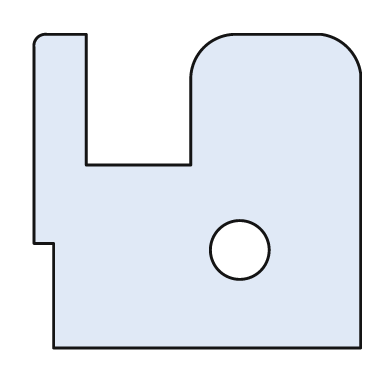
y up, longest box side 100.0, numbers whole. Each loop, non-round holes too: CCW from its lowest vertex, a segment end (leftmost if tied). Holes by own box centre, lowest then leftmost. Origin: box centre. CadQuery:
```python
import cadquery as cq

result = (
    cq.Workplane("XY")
    .moveTo(-44.0, -48.0)
    .lineTo(50.0, -48.0)
    .lineTo(50.0, 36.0)
    .threePointArc((46.0, 44.0), (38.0, 48.0))
    .lineTo(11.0, 48.0)
    .threePointArc((2.0, 44.0), (-2.0, 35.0))
    .lineTo(-2.0, 8.0)
    .lineTo(-34.0, 8.0)
    .lineTo(-34.0, 48.0)
    .lineTo(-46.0, 48.0)
    .threePointArc((-49.0, 47.0), (-50.0, 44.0))
    .lineTo(-50.0, -16.0)
    .lineTo(-44.0, -16.0)
    .close()
    .moveTo(13.0, -18.0)
    .circle(9.0)
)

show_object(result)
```